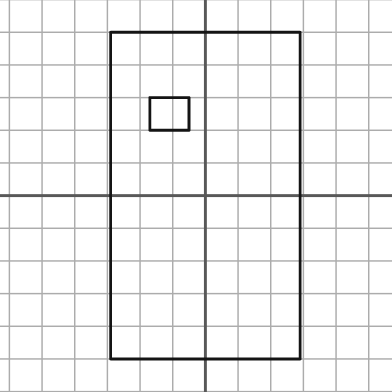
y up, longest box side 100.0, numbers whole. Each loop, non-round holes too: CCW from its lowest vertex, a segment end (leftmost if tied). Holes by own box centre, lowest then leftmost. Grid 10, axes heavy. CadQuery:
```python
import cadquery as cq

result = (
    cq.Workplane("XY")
    .moveTo(-29.0, -50.0)
    .lineTo(29.0, -50.0)
    .lineTo(29.0, 50.0)
    .lineTo(-29.0, 50.0)
    .close()
    .moveTo(-17.0, 20.0)
    .lineTo(-5.0, 20.0)
    .lineTo(-5.0, 30.0)
    .lineTo(-17.0, 30.0)
    .close()
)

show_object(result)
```